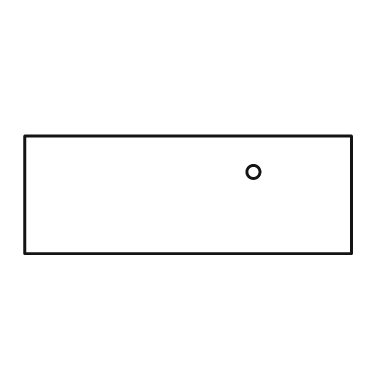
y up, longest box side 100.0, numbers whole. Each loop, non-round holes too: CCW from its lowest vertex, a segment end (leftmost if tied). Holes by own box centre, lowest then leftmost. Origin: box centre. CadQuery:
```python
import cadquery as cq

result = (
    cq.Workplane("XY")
    .moveTo(-50.0, -18.0)
    .lineTo(50.0, -18.0)
    .lineTo(50.0, 18.0)
    .lineTo(-50.0, 18.0)
    .close()
    .moveTo(20.0, 7.0)
    .circle(2.0)
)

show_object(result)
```